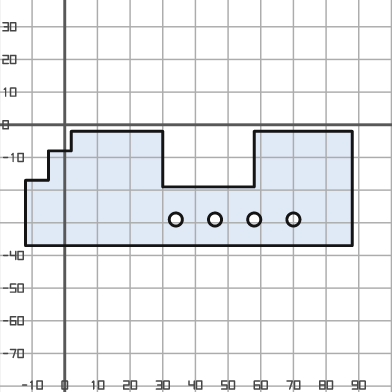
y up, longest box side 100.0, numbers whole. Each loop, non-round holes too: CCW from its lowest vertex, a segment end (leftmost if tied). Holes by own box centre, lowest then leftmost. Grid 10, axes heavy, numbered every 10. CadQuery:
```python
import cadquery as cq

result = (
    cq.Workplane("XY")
    .moveTo(-12.0, -37.0)
    .lineTo(88.0, -37.0)
    .lineTo(88.0, -2.0)
    .lineTo(58.0, -2.0)
    .lineTo(58.0, -19.0)
    .lineTo(30.0, -19.0)
    .lineTo(30.0, -2.0)
    .lineTo(2.0, -2.0)
    .lineTo(2.0, -8.0)
    .lineTo(-5.0, -8.0)
    .lineTo(-5.0, -17.0)
    .lineTo(-12.0, -17.0)
    .close()
    .moveTo(34.0, -29.0)
    .circle(2.0)
    .moveTo(46.0, -29.0)
    .circle(2.0)
    .moveTo(58.0, -29.0)
    .circle(2.0)
    .moveTo(70.0, -29.0)
    .circle(2.0)
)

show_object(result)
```